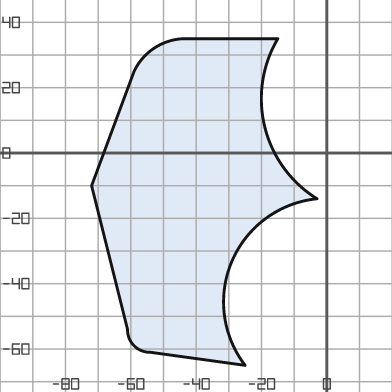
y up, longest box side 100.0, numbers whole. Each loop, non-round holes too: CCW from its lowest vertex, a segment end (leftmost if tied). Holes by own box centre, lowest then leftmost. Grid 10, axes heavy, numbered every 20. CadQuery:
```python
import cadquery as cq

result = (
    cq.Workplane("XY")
    .moveTo(-25.0, -65.0)
    .threePointArc((-29.0, -33.0), (-3.0, -14.0))
    .threePointArc((-19.0, 8.0), (-15.0, 35.0))
    .lineTo(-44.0, 35.0)
    .threePointArc((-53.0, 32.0), (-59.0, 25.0))
    .lineTo(-72.0, -10.0)
    .lineTo(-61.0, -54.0)
    .threePointArc((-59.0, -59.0), (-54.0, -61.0))
    .close()
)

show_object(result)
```